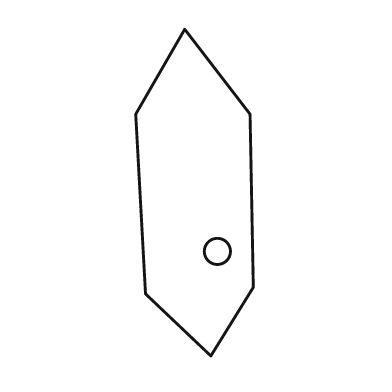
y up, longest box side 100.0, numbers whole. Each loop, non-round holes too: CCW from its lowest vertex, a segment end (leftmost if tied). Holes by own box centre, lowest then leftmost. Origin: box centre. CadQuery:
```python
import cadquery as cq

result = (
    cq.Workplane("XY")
    .moveTo(5.0, -50.0)
    .lineTo(18.0, -29.0)
    .lineTo(17.0, 24.0)
    .lineTo(-3.0, 50.0)
    .lineTo(-18.0, 24.0)
    .lineTo(-15.0, -31.0)
    .close()
    .moveTo(7.0, -18.0)
    .circle(4.0)
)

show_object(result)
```